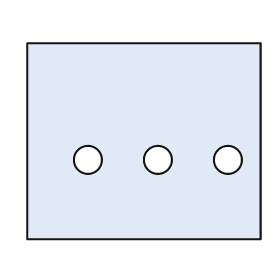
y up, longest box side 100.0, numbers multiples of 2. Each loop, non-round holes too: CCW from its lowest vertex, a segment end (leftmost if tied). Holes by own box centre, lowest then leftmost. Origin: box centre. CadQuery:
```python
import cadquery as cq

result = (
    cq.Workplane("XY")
    .moveTo(-50.0, -42.0)
    .lineTo(50.0, -42.0)
    .lineTo(50.0, 42.0)
    .lineTo(-50.0, 42.0)
    .close()
    .moveTo(-24.0, -8.0)
    .circle(6.0)
    .moveTo(6.0, -8.0)
    .circle(6.0)
    .moveTo(36.0, -8.0)
    .circle(6.0)
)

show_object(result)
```